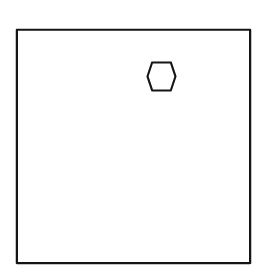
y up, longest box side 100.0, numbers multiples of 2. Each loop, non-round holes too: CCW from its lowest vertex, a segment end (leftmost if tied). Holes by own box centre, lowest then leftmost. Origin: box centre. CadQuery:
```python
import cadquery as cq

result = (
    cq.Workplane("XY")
    .moveTo(-50.0, -50.0)
    .lineTo(50.0, -50.0)
    .lineTo(50.0, 50.0)
    .lineTo(-50.0, 50.0)
    .close()
    .moveTo(8.0, 24.0)
    .lineTo(16.0, 24.0)
    .lineTo(18.0, 30.0)
    .lineTo(16.0, 36.0)
    .lineTo(8.0, 36.0)
    .lineTo(6.0, 30.0)
    .close()
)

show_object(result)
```